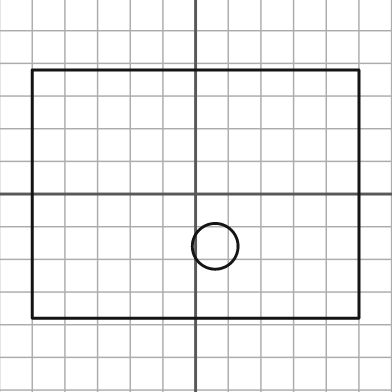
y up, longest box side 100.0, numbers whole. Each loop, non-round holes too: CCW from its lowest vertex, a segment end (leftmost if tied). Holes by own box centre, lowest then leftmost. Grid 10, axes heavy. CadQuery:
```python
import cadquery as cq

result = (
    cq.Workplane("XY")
    .moveTo(-50.0, -38.0)
    .lineTo(50.0, -38.0)
    .lineTo(50.0, 38.0)
    .lineTo(-50.0, 38.0)
    .close()
    .moveTo(6.0, -16.0)
    .circle(7.0)
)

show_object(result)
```